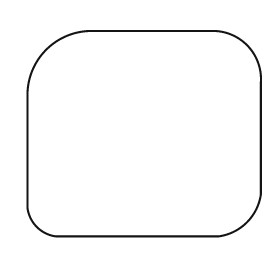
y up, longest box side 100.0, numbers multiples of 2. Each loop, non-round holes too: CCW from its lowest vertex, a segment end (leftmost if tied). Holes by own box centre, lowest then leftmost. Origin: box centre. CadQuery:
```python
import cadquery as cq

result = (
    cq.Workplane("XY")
    .moveTo(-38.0, -44.0)
    .lineTo(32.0, -44.0)
    .threePointArc((44.0, -38.0), (50.0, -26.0))
    .lineTo(50.0, 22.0)
    .threePointArc((44.0, 38.0), (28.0, 44.0))
    .lineTo(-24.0, 44.0)
    .threePointArc((-42.0, 36.0), (-50.0, 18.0))
    .lineTo(-50.0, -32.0)
    .threePointArc((-46.0, -40.0), (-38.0, -44.0))
    .close()
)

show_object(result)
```